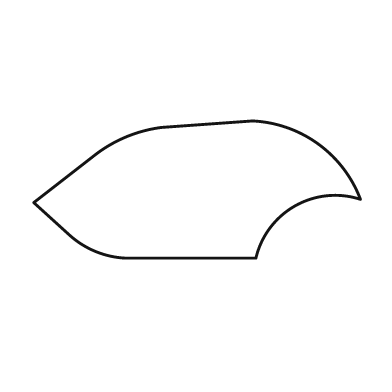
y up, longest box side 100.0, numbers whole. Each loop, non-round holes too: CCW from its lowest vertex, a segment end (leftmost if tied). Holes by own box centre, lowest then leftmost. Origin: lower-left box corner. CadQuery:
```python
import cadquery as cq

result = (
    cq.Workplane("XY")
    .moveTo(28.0, 0.0)
    .lineTo(68.0, 0.0)
    .threePointArc((80.0, 16.0), (100.0, 18.0))
    .threePointArc((87.0, 35.0), (67.0, 42.0))
    .lineTo(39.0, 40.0)
    .threePointArc((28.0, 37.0), (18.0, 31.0))
    .lineTo(0.0, 17.0)
    .lineTo(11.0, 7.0)
    .threePointArc((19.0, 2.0), (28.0, 0.0))
    .close()
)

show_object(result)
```